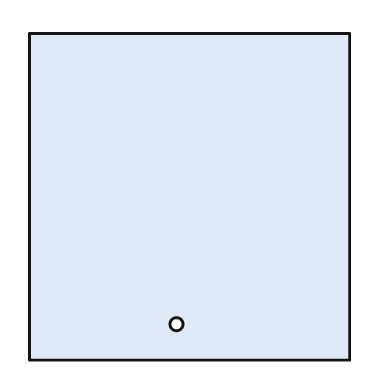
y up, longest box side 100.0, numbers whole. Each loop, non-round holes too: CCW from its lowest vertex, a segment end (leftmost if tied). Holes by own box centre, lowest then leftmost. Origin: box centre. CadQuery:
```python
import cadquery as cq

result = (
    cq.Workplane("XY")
    .moveTo(-49.0, -50.0)
    .lineTo(49.0, -50.0)
    .lineTo(49.0, 50.0)
    .lineTo(-49.0, 50.0)
    .close()
    .moveTo(-4.0, -39.0)
    .circle(2.0)
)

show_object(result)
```